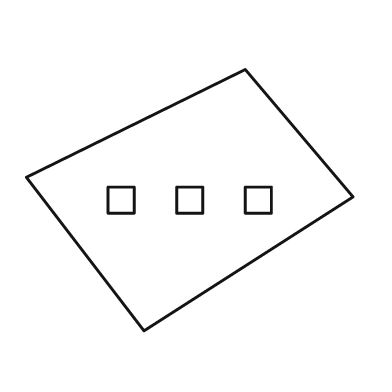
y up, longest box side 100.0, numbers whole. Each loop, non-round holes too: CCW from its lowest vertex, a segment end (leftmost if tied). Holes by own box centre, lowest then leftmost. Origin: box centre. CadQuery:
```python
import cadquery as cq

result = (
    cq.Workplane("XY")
    .moveTo(-14.0, -40.0)
    .lineTo(50.0, 1.0)
    .lineTo(17.0, 40.0)
    .lineTo(-50.0, 7.0)
    .close()
    .moveTo(-25.0, -4.0)
    .lineTo(-17.0, -4.0)
    .lineTo(-17.0, 4.0)
    .lineTo(-25.0, 4.0)
    .close()
    .moveTo(-4.0, -4.0)
    .lineTo(4.0, -4.0)
    .lineTo(4.0, 4.0)
    .lineTo(-4.0, 4.0)
    .close()
    .moveTo(17.0, -4.0)
    .lineTo(25.0, -4.0)
    .lineTo(25.0, 4.0)
    .lineTo(17.0, 4.0)
    .close()
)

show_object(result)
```